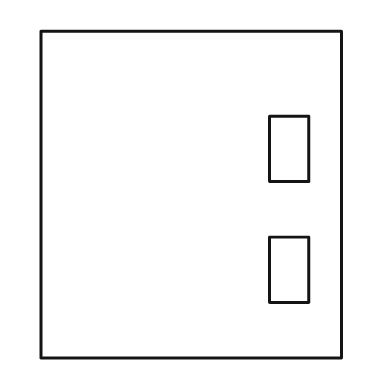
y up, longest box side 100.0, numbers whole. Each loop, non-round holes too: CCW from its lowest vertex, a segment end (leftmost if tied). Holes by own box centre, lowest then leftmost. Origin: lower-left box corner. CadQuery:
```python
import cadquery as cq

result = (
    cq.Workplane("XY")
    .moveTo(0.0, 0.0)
    .lineTo(92.0, 0.0)
    .lineTo(92.0, 100.0)
    .lineTo(0.0, 100.0)
    .close()
    .moveTo(70.0, 17.0)
    .lineTo(82.0, 17.0)
    .lineTo(82.0, 37.0)
    .lineTo(70.0, 37.0)
    .close()
    .moveTo(70.0, 54.0)
    .lineTo(82.0, 54.0)
    .lineTo(82.0, 74.0)
    .lineTo(70.0, 74.0)
    .close()
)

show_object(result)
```